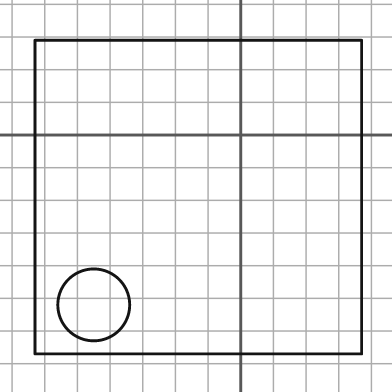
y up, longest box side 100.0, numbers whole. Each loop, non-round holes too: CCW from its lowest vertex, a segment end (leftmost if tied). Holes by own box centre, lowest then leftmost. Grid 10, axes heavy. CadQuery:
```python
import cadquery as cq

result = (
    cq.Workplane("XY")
    .moveTo(-63.0, -67.0)
    .lineTo(37.0, -67.0)
    .lineTo(37.0, 29.0)
    .lineTo(-63.0, 29.0)
    .close()
    .moveTo(-45.0, -52.0)
    .circle(11.0)
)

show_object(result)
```